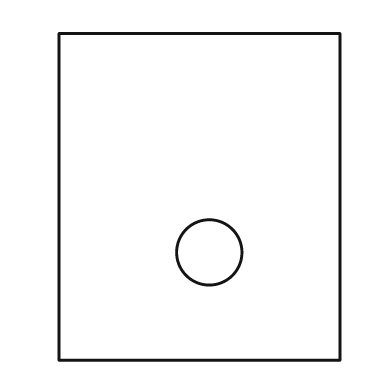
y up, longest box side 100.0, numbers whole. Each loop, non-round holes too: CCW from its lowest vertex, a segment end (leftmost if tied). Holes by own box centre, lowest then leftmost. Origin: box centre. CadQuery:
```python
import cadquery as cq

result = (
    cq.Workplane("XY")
    .moveTo(-43.0, -50.0)
    .lineTo(43.0, -50.0)
    .lineTo(43.0, 50.0)
    .lineTo(-43.0, 50.0)
    .close()
    .moveTo(3.0, -17.0)
    .circle(10.0)
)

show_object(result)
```